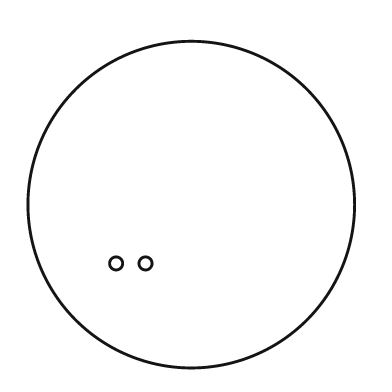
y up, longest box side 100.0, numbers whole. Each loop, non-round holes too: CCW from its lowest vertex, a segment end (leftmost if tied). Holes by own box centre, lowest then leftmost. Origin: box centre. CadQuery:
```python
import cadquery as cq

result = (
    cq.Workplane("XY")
    .moveTo(0.0, 0.0)
    .circle(50.0)
    .moveTo(-23.0, -18.0)
    .circle(2.0)
    .moveTo(-14.0, -18.0)
    .circle(2.0)
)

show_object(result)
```